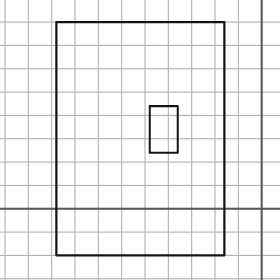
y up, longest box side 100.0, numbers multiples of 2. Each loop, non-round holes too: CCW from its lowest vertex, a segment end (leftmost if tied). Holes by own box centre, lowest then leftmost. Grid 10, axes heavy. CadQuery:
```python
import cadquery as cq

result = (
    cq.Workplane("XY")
    .moveTo(-88.0, -20.0)
    .lineTo(-16.0, -20.0)
    .lineTo(-16.0, 80.0)
    .lineTo(-88.0, 80.0)
    .close()
    .moveTo(-48.0, 24.0)
    .lineTo(-36.0, 24.0)
    .lineTo(-36.0, 44.0)
    .lineTo(-48.0, 44.0)
    .close()
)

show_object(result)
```